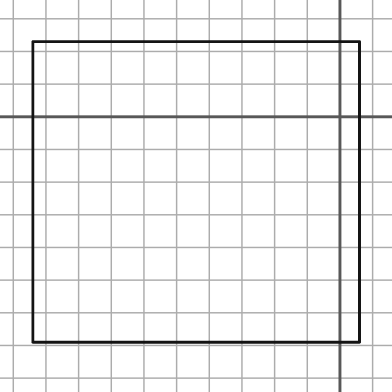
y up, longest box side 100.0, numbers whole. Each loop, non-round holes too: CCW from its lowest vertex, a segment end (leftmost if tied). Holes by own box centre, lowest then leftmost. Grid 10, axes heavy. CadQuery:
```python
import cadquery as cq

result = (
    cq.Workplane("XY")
    .moveTo(-94.0, -69.0)
    .lineTo(6.0, -69.0)
    .lineTo(6.0, 23.0)
    .lineTo(-94.0, 23.0)
    .close()
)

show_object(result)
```